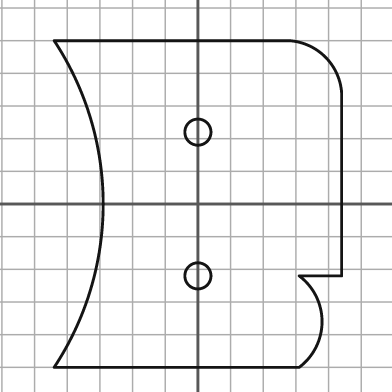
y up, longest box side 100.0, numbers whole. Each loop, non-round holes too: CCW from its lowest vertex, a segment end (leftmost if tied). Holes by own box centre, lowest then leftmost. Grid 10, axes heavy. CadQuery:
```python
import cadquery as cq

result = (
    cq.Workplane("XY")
    .moveTo(-44.0, -50.0)
    .lineTo(31.0, -50.0)
    .threePointArc((38.0, -36.0), (31.0, -22.0))
    .lineTo(44.0, -22.0)
    .lineTo(44.0, 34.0)
    .threePointArc((39.0, 45.0), (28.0, 50.0))
    .lineTo(-44.0, 50.0)
    .threePointArc((-29.0, 0.0), (-44.0, -50.0))
    .close()
    .moveTo(0.0, -22.0)
    .circle(4.0)
    .moveTo(0.0, 22.0)
    .circle(4.0)
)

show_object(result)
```